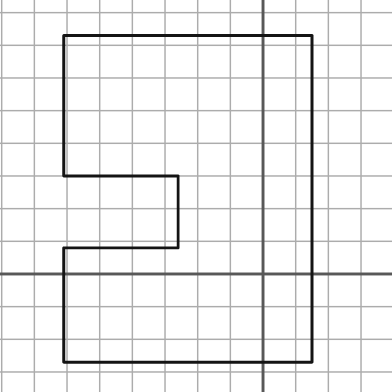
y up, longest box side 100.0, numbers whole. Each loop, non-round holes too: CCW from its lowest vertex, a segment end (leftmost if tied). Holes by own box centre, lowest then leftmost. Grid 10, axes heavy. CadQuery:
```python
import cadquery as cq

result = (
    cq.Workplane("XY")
    .moveTo(-61.0, -27.0)
    .lineTo(15.0, -27.0)
    .lineTo(15.0, 73.0)
    .lineTo(-61.0, 73.0)
    .lineTo(-61.0, 30.0)
    .lineTo(-26.0, 30.0)
    .lineTo(-26.0, 8.0)
    .lineTo(-61.0, 8.0)
    .close()
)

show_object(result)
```